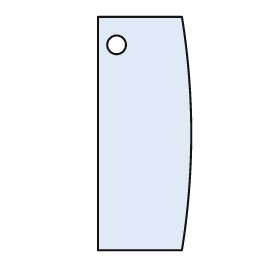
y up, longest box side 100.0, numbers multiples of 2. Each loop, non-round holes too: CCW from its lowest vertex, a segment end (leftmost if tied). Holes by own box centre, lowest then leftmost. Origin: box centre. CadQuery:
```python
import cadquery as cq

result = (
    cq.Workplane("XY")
    .moveTo(-20.0, -50.0)
    .lineTo(16.0, -50.0)
    .threePointArc((20.0, 0.0), (16.0, 50.0))
    .lineTo(-20.0, 50.0)
    .close()
    .moveTo(-12.0, 38.0)
    .circle(4.0)
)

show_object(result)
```